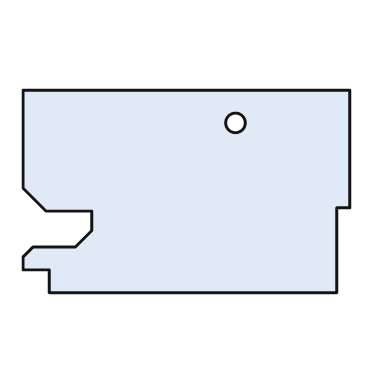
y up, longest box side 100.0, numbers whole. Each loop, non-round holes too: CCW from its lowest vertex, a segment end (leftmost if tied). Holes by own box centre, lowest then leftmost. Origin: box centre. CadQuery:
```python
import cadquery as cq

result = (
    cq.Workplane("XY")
    .moveTo(-42.0, -31.0)
    .lineTo(46.0, -31.0)
    .lineTo(46.0, -5.0)
    .lineTo(50.0, -5.0)
    .lineTo(50.0, 31.0)
    .lineTo(-50.0, 31.0)
    .lineTo(-50.0, 1.0)
    .lineTo(-43.0, -6.0)
    .lineTo(-29.0, -6.0)
    .lineTo(-29.0, -12.0)
    .lineTo(-34.0, -17.0)
    .lineTo(-47.0, -17.0)
    .lineTo(-50.0, -20.0)
    .lineTo(-50.0, -24.0)
    .lineTo(-42.0, -24.0)
    .close()
    .moveTo(15.0, 21.0)
    .circle(3.0)
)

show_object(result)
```